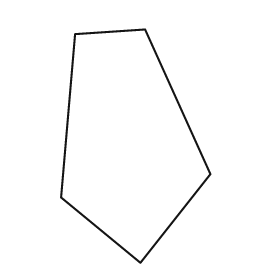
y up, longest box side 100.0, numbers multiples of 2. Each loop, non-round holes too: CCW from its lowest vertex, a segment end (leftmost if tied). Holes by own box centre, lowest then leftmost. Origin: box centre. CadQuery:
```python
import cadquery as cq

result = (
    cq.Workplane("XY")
    .moveTo(2.0, -50.0)
    .lineTo(32.0, -12.0)
    .lineTo(4.0, 50.0)
    .lineTo(-26.0, 48.0)
    .lineTo(-32.0, -22.0)
    .close()
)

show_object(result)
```